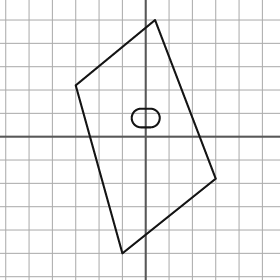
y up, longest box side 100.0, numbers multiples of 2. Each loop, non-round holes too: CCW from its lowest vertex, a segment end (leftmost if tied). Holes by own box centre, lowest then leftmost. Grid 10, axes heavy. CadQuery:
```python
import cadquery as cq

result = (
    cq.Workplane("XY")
    .moveTo(-10.0, -50.0)
    .lineTo(30.0, -18.0)
    .lineTo(4.0, 50.0)
    .lineTo(-30.0, 22.0)
    .close()
    .moveTo(-2.0, 4.0)
    .lineTo(2.0, 4.0)
    .threePointArc((6.0, 8.0), (2.0, 12.0))
    .lineTo(-2.0, 12.0)
    .threePointArc((-6.0, 8.0), (-2.0, 4.0))
    .close()
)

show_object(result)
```